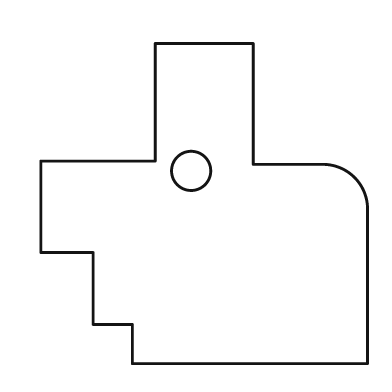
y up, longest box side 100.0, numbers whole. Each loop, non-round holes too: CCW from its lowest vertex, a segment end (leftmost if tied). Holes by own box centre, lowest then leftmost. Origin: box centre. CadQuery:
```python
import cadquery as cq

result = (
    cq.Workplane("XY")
    .moveTo(-22.0, -49.0)
    .lineTo(50.0, -49.0)
    .lineTo(50.0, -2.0)
    .threePointArc((46.0, 8.0), (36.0, 12.0))
    .lineTo(15.0, 12.0)
    .lineTo(15.0, 49.0)
    .lineTo(-15.0, 49.0)
    .lineTo(-15.0, 13.0)
    .lineTo(-50.0, 13.0)
    .lineTo(-50.0, -15.0)
    .lineTo(-34.0, -15.0)
    .lineTo(-34.0, -37.0)
    .lineTo(-22.0, -37.0)
    .close()
    .moveTo(-4.0, 10.0)
    .circle(6.0)
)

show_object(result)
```